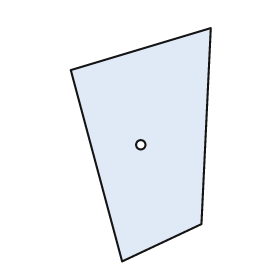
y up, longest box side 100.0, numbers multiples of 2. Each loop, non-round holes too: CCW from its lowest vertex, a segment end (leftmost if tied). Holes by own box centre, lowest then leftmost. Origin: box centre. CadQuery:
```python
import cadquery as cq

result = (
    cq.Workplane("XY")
    .moveTo(-8.0, -50.0)
    .lineTo(26.0, -34.0)
    .lineTo(30.0, 50.0)
    .lineTo(-30.0, 32.0)
    .close()
    .moveTo(0.0, 0.0)
    .circle(2.0)
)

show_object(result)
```